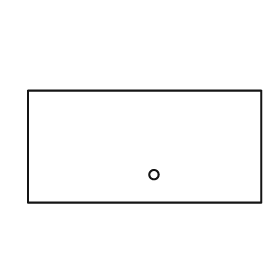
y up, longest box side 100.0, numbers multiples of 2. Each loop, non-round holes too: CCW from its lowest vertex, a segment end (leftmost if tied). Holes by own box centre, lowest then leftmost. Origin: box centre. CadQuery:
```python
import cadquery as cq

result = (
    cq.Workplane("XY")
    .moveTo(-50.0, -24.0)
    .lineTo(50.0, -24.0)
    .lineTo(50.0, 24.0)
    .lineTo(-50.0, 24.0)
    .close()
    .moveTo(4.0, -12.0)
    .circle(2.0)
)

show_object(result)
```